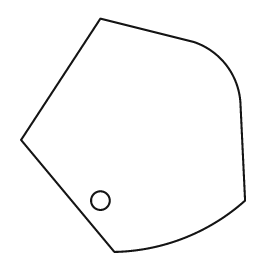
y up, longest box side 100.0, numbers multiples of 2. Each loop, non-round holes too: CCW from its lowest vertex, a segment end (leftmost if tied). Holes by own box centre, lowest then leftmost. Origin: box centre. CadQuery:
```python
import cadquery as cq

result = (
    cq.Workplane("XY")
    .moveTo(-8.0, -50.0)
    .threePointArc((22.0, -44.0), (48.0, -28.0))
    .lineTo(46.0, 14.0)
    .threePointArc((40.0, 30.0), (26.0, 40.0))
    .lineTo(-14.0, 50.0)
    .lineTo(-48.0, -2.0)
    .close()
    .moveTo(-14.0, -28.0)
    .circle(4.0)
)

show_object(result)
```